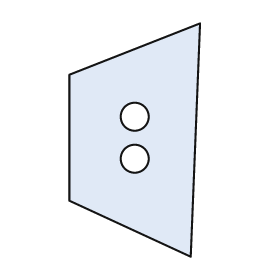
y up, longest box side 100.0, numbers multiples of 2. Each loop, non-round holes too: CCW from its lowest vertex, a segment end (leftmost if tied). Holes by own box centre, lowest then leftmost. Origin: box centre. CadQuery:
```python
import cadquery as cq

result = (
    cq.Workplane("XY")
    .moveTo(24.0, -50.0)
    .lineTo(28.0, 50.0)
    .lineTo(-28.0, 28.0)
    .lineTo(-28.0, -26.0)
    .close()
    .moveTo(0.0, -8.0)
    .circle(6.0)
    .moveTo(0.0, 10.0)
    .circle(6.0)
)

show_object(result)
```